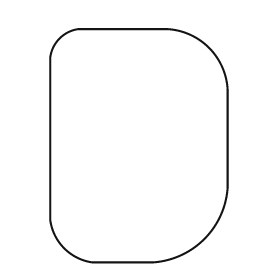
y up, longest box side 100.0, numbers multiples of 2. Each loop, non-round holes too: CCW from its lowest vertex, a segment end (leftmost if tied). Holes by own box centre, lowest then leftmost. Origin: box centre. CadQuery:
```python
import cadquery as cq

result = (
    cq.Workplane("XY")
    .moveTo(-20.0, -50.0)
    .lineTo(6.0, -50.0)
    .threePointArc((28.0, -40.0), (38.0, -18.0))
    .lineTo(38.0, 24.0)
    .threePointArc((30.0, 42.0), (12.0, 50.0))
    .lineTo(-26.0, 50.0)
    .threePointArc((-34.0, 46.0), (-38.0, 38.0))
    .lineTo(-38.0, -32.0)
    .threePointArc((-32.0, -44.0), (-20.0, -50.0))
    .close()
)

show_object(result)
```